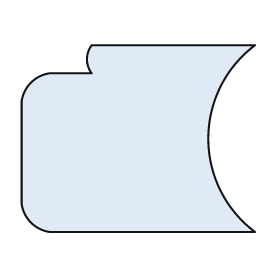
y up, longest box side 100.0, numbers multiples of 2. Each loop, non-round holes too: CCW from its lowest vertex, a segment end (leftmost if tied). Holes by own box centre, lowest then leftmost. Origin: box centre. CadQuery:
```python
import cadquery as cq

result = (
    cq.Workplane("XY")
    .moveTo(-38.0, -40.0)
    .lineTo(50.0, -40.0)
    .threePointArc((30.0, 0.0), (50.0, 40.0))
    .lineTo(-20.0, 40.0)
    .threePointArc((-22.0, 34.0), (-20.0, 28.0))
    .lineTo(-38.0, 28.0)
    .threePointArc((-46.0, 24.0), (-50.0, 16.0))
    .lineTo(-50.0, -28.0)
    .threePointArc((-46.0, -36.0), (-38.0, -40.0))
    .close()
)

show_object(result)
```